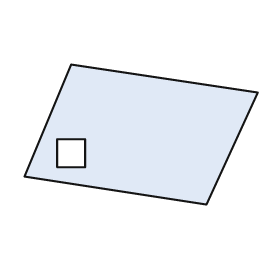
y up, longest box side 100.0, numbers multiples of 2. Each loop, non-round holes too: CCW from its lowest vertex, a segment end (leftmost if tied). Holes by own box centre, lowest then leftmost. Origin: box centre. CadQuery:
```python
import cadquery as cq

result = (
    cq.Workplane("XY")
    .moveTo(28.0, -30.0)
    .lineTo(50.0, 18.0)
    .lineTo(-30.0, 30.0)
    .lineTo(-50.0, -18.0)
    .close()
    .moveTo(-36.0, -14.0)
    .lineTo(-24.0, -14.0)
    .lineTo(-24.0, -2.0)
    .lineTo(-36.0, -2.0)
    .close()
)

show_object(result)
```